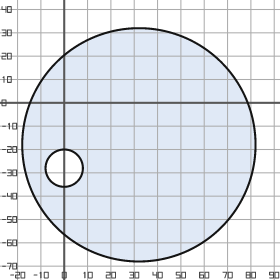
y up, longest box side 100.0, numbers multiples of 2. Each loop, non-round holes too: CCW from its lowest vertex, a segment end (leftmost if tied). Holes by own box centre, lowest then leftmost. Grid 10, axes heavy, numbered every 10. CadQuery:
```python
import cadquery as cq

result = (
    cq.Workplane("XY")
    .moveTo(32.0, -18.0)
    .circle(50.0)
    .moveTo(0.0, -28.0)
    .circle(8.0)
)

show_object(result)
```